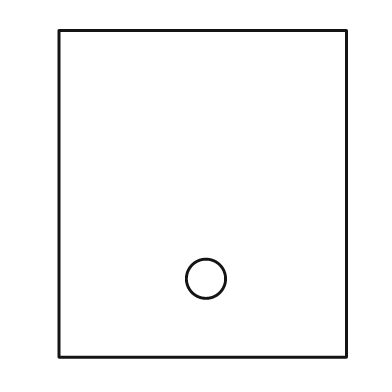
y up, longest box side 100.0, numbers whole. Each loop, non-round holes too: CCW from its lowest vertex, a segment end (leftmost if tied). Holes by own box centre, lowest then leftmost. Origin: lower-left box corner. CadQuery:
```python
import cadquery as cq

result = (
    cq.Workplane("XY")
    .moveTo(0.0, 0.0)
    .lineTo(88.0, 0.0)
    .lineTo(88.0, 100.0)
    .lineTo(0.0, 100.0)
    .close()
    .moveTo(45.0, 24.0)
    .circle(6.0)
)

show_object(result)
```